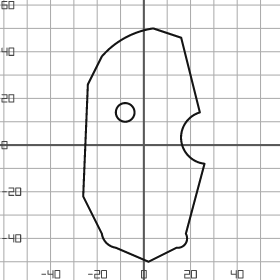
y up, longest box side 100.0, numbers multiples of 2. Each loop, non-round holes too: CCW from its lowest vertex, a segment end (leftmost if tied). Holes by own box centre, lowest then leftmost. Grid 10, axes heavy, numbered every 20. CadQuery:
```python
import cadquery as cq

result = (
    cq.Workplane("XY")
    .moveTo(2.0, -50.0)
    .lineTo(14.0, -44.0)
    .threePointArc((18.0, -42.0), (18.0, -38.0))
    .lineTo(26.0, -8.0)
    .threePointArc((16.0, 2.0), (24.0, 14.0))
    .lineTo(16.0, 46.0)
    .lineTo(4.0, 50.0)
    .threePointArc((-8.0, 46.0), (-18.0, 38.0))
    .lineTo(-24.0, 26.0)
    .lineTo(-26.0, -22.0)
    .lineTo(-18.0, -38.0)
    .threePointArc((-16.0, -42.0), (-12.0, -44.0))
    .close()
    .moveTo(-8.0, 14.0)
    .circle(4.0)
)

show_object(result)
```